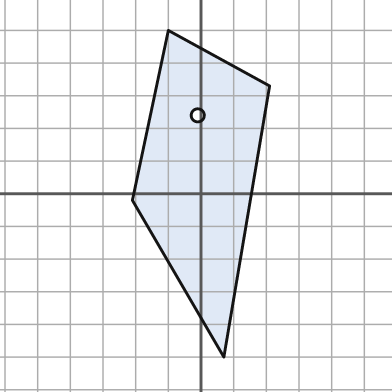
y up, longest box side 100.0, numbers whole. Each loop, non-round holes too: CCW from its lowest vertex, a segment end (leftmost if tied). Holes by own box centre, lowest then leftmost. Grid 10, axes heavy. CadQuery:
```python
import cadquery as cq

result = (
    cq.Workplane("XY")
    .moveTo(7.0, -50.0)
    .lineTo(21.0, 33.0)
    .lineTo(-10.0, 50.0)
    .lineTo(-21.0, -2.0)
    .close()
    .moveTo(-1.0, 24.0)
    .circle(2.0)
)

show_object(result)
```